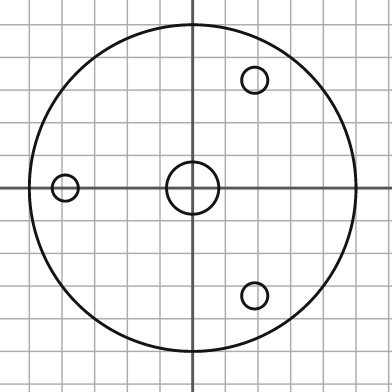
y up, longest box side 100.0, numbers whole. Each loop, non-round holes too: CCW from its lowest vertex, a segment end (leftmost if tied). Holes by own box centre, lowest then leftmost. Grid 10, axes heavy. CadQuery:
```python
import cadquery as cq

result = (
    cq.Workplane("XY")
    .moveTo(0.0, 0.0)
    .circle(50.0)
    .moveTo(19.0, -33.0)
    .circle(4.0)
    .moveTo(-39.0, 0.0)
    .circle(4.0)
    .moveTo(0.0, 0.0)
    .circle(8.0)
    .moveTo(19.0, 33.0)
    .circle(4.0)
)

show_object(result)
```